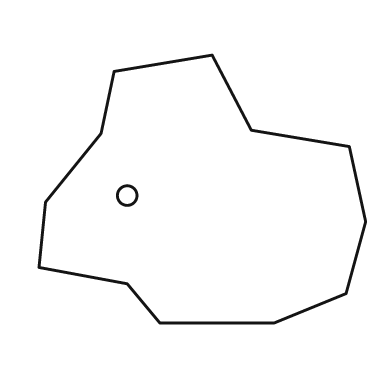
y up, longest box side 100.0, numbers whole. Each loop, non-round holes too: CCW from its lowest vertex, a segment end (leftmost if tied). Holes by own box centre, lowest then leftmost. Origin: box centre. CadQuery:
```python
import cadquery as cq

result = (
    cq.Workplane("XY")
    .moveTo(-13.0, -41.0)
    .lineTo(22.0, -41.0)
    .lineTo(44.0, -32.0)
    .lineTo(50.0, -10.0)
    .lineTo(45.0, 13.0)
    .lineTo(15.0, 18.0)
    .lineTo(3.0, 41.0)
    .lineTo(-27.0, 36.0)
    .lineTo(-31.0, 17.0)
    .lineTo(-48.0, -4.0)
    .lineTo(-50.0, -24.0)
    .lineTo(-23.0, -29.0)
    .close()
    .moveTo(-23.0, -2.0)
    .circle(3.0)
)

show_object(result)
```